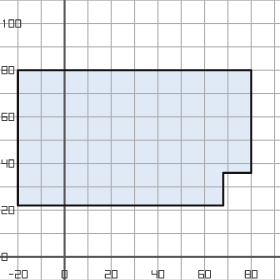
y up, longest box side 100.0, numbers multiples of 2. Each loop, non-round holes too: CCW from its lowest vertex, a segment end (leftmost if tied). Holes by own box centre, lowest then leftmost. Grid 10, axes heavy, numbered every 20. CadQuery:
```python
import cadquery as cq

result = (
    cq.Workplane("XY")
    .moveTo(-20.0, 22.0)
    .lineTo(68.0, 22.0)
    .lineTo(68.0, 36.0)
    .lineTo(80.0, 36.0)
    .lineTo(80.0, 80.0)
    .lineTo(-20.0, 80.0)
    .close()
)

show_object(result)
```